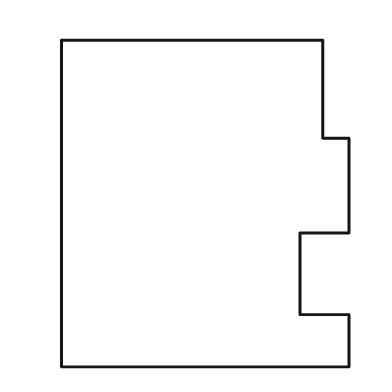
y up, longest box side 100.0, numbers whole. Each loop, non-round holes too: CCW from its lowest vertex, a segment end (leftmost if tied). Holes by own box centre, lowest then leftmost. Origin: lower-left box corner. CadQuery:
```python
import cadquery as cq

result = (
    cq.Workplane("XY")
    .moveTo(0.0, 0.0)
    .lineTo(88.0, 0.0)
    .lineTo(88.0, 16.0)
    .lineTo(73.0, 16.0)
    .lineTo(73.0, 41.0)
    .lineTo(88.0, 41.0)
    .lineTo(88.0, 70.0)
    .lineTo(80.0, 70.0)
    .lineTo(80.0, 100.0)
    .lineTo(0.0, 100.0)
    .close()
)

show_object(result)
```